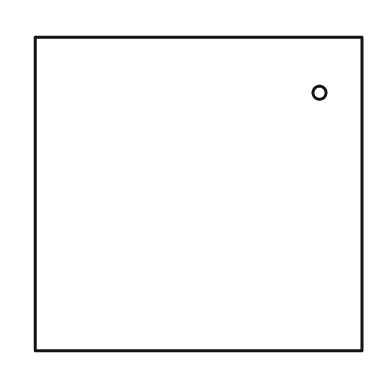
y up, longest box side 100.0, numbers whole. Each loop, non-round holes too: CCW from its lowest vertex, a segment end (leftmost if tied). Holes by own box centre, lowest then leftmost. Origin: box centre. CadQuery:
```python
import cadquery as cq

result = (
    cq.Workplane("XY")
    .moveTo(-50.0, -48.0)
    .lineTo(50.0, -48.0)
    .lineTo(50.0, 48.0)
    .lineTo(-50.0, 48.0)
    .close()
    .moveTo(37.0, 31.0)
    .circle(2.0)
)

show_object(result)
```